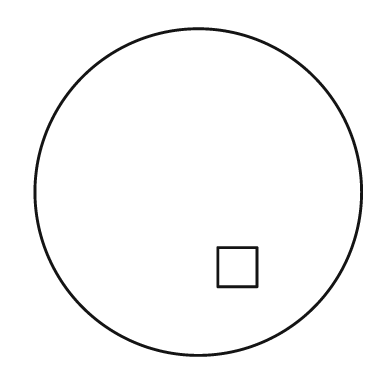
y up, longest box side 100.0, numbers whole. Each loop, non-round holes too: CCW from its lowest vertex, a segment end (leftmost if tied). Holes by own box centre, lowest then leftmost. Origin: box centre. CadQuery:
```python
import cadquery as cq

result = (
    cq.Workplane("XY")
    .moveTo(0.0, 0.0)
    .circle(50.0)
    .moveTo(6.0, -29.0)
    .lineTo(18.0, -29.0)
    .lineTo(18.0, -17.0)
    .lineTo(6.0, -17.0)
    .close()
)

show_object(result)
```